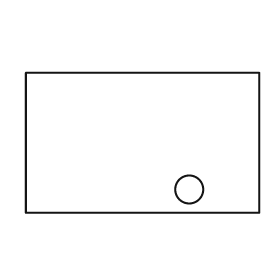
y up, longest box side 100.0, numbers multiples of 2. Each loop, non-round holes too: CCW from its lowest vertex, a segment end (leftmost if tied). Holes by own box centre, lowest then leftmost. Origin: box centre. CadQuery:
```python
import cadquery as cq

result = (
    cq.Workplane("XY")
    .moveTo(-50.0, -30.0)
    .lineTo(50.0, -30.0)
    .lineTo(50.0, 30.0)
    .lineTo(-50.0, 30.0)
    .close()
    .moveTo(20.0, -20.0)
    .circle(6.0)
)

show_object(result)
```